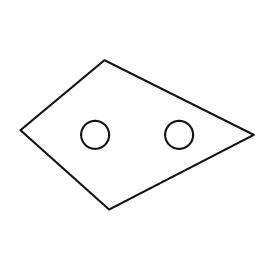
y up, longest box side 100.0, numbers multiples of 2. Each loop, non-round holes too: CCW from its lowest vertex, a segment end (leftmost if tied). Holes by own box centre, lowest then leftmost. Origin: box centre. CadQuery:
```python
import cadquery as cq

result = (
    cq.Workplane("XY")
    .moveTo(-12.0, -32.0)
    .lineTo(50.0, 0.0)
    .lineTo(-14.0, 32.0)
    .lineTo(-50.0, 2.0)
    .close()
    .moveTo(-18.0, 0.0)
    .circle(6.0)
    .moveTo(18.0, 0.0)
    .circle(6.0)
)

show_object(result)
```